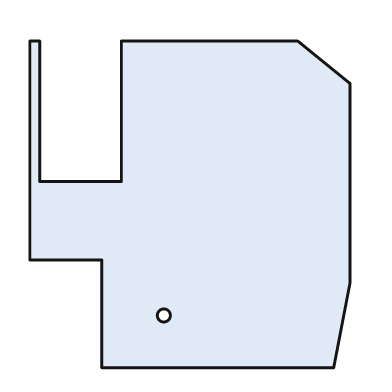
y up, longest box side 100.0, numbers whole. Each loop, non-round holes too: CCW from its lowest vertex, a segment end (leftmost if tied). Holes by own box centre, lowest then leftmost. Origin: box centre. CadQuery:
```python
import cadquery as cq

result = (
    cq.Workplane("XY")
    .moveTo(-27.0, -50.0)
    .lineTo(44.0, -50.0)
    .lineTo(49.0, -24.0)
    .lineTo(49.0, 37.0)
    .lineTo(33.0, 50.0)
    .lineTo(-21.0, 50.0)
    .lineTo(-21.0, 7.0)
    .lineTo(-46.0, 7.0)
    .lineTo(-46.0, 50.0)
    .lineTo(-49.0, 50.0)
    .lineTo(-49.0, -17.0)
    .lineTo(-27.0, -17.0)
    .close()
    .moveTo(-8.0, -34.0)
    .circle(2.0)
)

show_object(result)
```